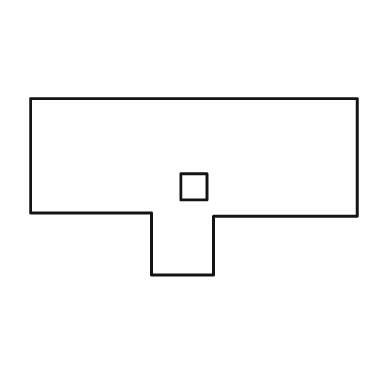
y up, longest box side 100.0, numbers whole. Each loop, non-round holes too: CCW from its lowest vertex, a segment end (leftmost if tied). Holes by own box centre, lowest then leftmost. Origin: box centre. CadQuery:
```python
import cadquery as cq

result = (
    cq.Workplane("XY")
    .moveTo(-13.0, -27.0)
    .lineTo(6.0, -27.0)
    .lineTo(6.0, -9.0)
    .lineTo(50.0, -9.0)
    .lineTo(50.0, 27.0)
    .lineTo(-50.0, 27.0)
    .lineTo(-50.0, -8.0)
    .lineTo(-13.0, -8.0)
    .close()
    .moveTo(-4.0, -4.0)
    .lineTo(4.0, -4.0)
    .lineTo(4.0, 4.0)
    .lineTo(-4.0, 4.0)
    .close()
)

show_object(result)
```